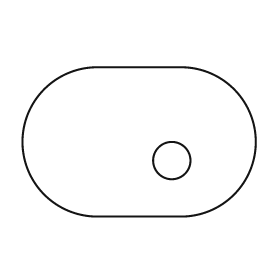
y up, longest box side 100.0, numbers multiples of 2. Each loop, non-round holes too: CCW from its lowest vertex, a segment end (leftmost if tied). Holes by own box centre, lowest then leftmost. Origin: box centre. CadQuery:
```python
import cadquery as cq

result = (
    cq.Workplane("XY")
    .moveTo(-18.0, -32.0)
    .lineTo(18.0, -32.0)
    .threePointArc((50.0, 0.0), (18.0, 32.0))
    .lineTo(-18.0, 32.0)
    .threePointArc((-50.0, 0.0), (-18.0, -32.0))
    .close()
    .moveTo(14.0, -8.0)
    .circle(8.0)
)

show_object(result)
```